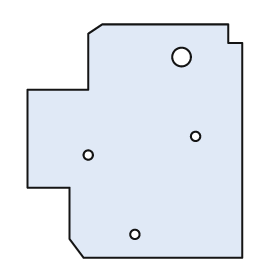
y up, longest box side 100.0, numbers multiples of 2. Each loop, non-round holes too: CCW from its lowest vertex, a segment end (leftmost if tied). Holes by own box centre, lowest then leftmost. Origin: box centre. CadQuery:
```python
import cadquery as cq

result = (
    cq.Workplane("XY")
    .moveTo(-22.0, -50.0)
    .lineTo(46.0, -50.0)
    .lineTo(46.0, 42.0)
    .lineTo(40.0, 42.0)
    .lineTo(40.0, 50.0)
    .lineTo(-14.0, 50.0)
    .lineTo(-20.0, 46.0)
    .lineTo(-20.0, 22.0)
    .lineTo(-46.0, 22.0)
    .lineTo(-46.0, -20.0)
    .lineTo(-28.0, -20.0)
    .lineTo(-28.0, -42.0)
    .close()
    .moveTo(0.0, -40.0)
    .circle(2.0)
    .moveTo(-20.0, -6.0)
    .circle(2.0)
    .moveTo(26.0, 2.0)
    .circle(2.0)
    .moveTo(20.0, 36.0)
    .circle(4.0)
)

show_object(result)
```